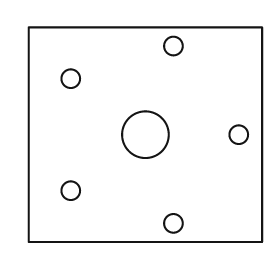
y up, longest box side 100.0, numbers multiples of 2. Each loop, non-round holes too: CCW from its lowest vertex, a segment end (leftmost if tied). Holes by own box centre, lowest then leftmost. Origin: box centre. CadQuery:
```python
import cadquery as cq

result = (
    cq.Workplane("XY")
    .moveTo(-50.0, -46.0)
    .lineTo(50.0, -46.0)
    .lineTo(50.0, 46.0)
    .lineTo(-50.0, 46.0)
    .close()
    .moveTo(12.0, -38.0)
    .circle(4.0)
    .moveTo(-32.0, -24.0)
    .circle(4.0)
    .moveTo(0.0, 0.0)
    .circle(10.0)
    .moveTo(40.0, 0.0)
    .circle(4.0)
    .moveTo(-32.0, 24.0)
    .circle(4.0)
    .moveTo(12.0, 38.0)
    .circle(4.0)
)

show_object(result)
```